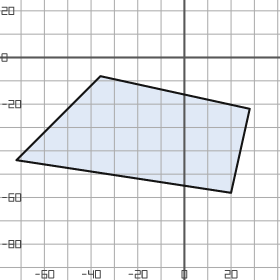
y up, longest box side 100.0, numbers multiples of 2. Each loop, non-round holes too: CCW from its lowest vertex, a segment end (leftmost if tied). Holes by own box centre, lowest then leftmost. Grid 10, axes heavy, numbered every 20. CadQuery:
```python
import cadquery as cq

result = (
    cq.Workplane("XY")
    .moveTo(20.0, -58.0)
    .lineTo(28.0, -22.0)
    .lineTo(-36.0, -8.0)
    .lineTo(-72.0, -44.0)
    .close()
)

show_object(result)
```